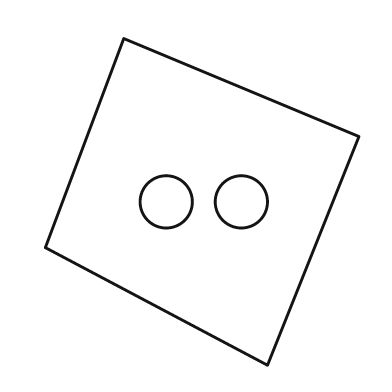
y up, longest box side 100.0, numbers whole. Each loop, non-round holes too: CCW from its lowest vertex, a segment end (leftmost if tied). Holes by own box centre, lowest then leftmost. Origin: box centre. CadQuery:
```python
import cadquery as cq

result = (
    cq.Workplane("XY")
    .moveTo(20.0, -50.0)
    .lineTo(48.0, 20.0)
    .lineTo(-24.0, 50.0)
    .lineTo(-48.0, -14.0)
    .close()
    .moveTo(-11.0, 0.0)
    .circle(8.0)
    .moveTo(12.0, 0.0)
    .circle(8.0)
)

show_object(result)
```